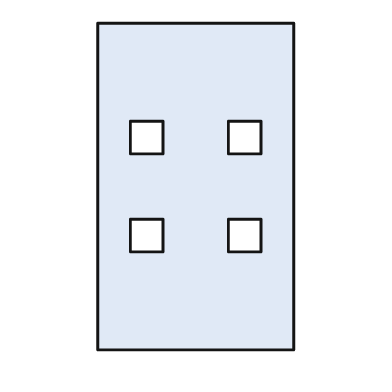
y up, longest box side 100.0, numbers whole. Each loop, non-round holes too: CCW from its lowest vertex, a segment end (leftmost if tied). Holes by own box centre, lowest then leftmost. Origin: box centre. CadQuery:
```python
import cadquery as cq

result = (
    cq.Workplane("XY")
    .moveTo(-30.0, -50.0)
    .lineTo(30.0, -50.0)
    .lineTo(30.0, 50.0)
    .lineTo(-30.0, 50.0)
    .close()
    .moveTo(-20.0, -20.0)
    .lineTo(-10.0, -20.0)
    .lineTo(-10.0, -10.0)
    .lineTo(-20.0, -10.0)
    .close()
    .moveTo(10.0, -20.0)
    .lineTo(20.0, -20.0)
    .lineTo(20.0, -10.0)
    .lineTo(10.0, -10.0)
    .close()
    .moveTo(-20.0, 10.0)
    .lineTo(-10.0, 10.0)
    .lineTo(-10.0, 20.0)
    .lineTo(-20.0, 20.0)
    .close()
    .moveTo(10.0, 10.0)
    .lineTo(20.0, 10.0)
    .lineTo(20.0, 20.0)
    .lineTo(10.0, 20.0)
    .close()
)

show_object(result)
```